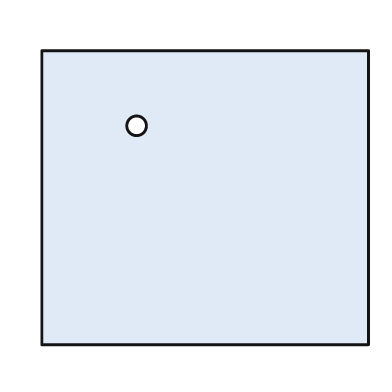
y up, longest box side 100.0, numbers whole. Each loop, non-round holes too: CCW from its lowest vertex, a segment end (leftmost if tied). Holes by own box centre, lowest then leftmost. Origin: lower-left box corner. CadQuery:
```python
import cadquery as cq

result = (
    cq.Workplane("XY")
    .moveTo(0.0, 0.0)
    .lineTo(100.0, 0.0)
    .lineTo(100.0, 90.0)
    .lineTo(0.0, 90.0)
    .close()
    .moveTo(29.0, 67.0)
    .circle(3.0)
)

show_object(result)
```